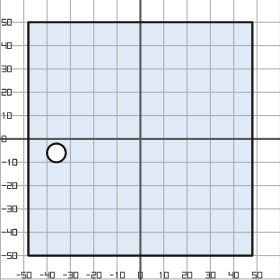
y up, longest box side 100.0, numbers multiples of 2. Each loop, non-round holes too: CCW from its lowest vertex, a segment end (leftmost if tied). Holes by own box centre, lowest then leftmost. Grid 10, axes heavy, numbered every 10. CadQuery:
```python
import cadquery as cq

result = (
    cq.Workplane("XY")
    .moveTo(-48.0, -50.0)
    .lineTo(48.0, -50.0)
    .lineTo(48.0, 50.0)
    .lineTo(-48.0, 50.0)
    .close()
    .moveTo(-36.0, -6.0)
    .circle(4.0)
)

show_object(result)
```